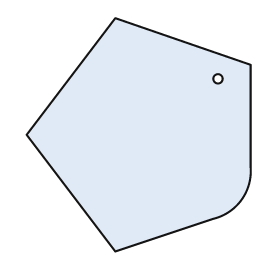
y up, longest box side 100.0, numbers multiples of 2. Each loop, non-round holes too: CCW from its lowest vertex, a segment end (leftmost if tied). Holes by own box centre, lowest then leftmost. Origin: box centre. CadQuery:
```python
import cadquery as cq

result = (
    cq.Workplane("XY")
    .moveTo(-10.0, -50.0)
    .lineTo(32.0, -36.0)
    .threePointArc((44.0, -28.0), (48.0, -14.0))
    .lineTo(48.0, 30.0)
    .lineTo(-10.0, 50.0)
    .lineTo(-48.0, 0.0)
    .close()
    .moveTo(34.0, 24.0)
    .circle(2.0)
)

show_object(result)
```